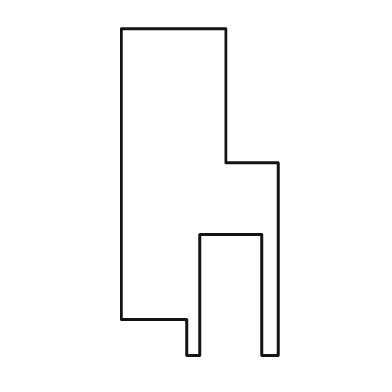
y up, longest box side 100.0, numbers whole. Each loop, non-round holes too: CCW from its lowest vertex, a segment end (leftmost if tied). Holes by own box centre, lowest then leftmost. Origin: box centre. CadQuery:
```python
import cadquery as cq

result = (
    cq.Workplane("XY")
    .moveTo(-4.0, -50.0)
    .lineTo(0.0, -50.0)
    .lineTo(0.0, -13.0)
    .lineTo(19.0, -13.0)
    .lineTo(19.0, -50.0)
    .lineTo(24.0, -50.0)
    .lineTo(24.0, 9.0)
    .lineTo(8.0, 9.0)
    .lineTo(8.0, 50.0)
    .lineTo(-24.0, 50.0)
    .lineTo(-24.0, -39.0)
    .lineTo(-4.0, -39.0)
    .close()
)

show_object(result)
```